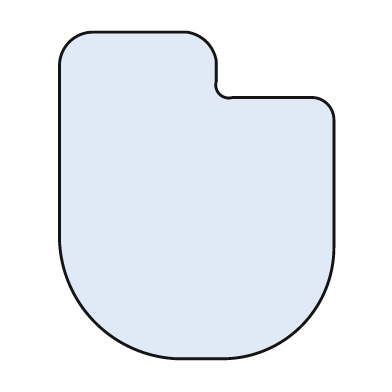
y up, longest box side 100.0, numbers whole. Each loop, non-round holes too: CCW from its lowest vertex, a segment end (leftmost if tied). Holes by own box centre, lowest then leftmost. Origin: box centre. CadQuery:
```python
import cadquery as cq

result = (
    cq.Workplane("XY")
    .moveTo(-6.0, -50.0)
    .lineTo(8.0, -50.0)
    .threePointArc((32.0, -40.0), (42.0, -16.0))
    .lineTo(42.0, 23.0)
    .threePointArc((40.0, 28.0), (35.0, 30.0))
    .lineTo(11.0, 30.0)
    .threePointArc((7.0, 31.0), (6.0, 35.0))
    .lineTo(6.0, 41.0)
    .threePointArc((3.0, 47.0), (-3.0, 50.0))
    .lineTo(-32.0, 50.0)
    .threePointArc((-39.0, 47.0), (-42.0, 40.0))
    .lineTo(-42.0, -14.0)
    .threePointArc((-31.0, -39.0), (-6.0, -50.0))
    .close()
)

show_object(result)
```